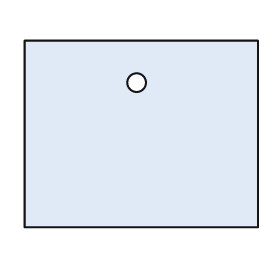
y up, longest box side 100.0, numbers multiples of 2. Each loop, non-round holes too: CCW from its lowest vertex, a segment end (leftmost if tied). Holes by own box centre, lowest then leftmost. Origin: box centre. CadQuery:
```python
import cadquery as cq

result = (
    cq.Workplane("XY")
    .moveTo(-50.0, -40.0)
    .lineTo(50.0, -40.0)
    .lineTo(50.0, 40.0)
    .lineTo(-50.0, 40.0)
    .close()
    .moveTo(-2.0, 22.0)
    .circle(4.0)
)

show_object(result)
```